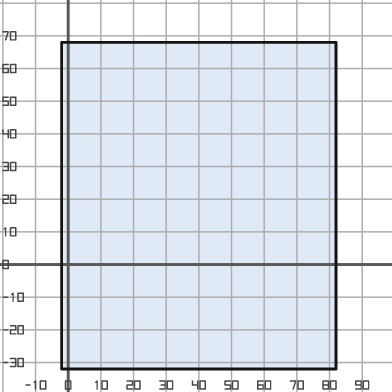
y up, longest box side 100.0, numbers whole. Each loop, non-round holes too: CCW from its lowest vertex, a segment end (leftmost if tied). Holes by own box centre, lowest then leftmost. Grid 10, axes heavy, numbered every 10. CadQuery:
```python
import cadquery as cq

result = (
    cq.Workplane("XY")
    .moveTo(-2.0, -32.0)
    .lineTo(82.0, -32.0)
    .lineTo(82.0, 68.0)
    .lineTo(-2.0, 68.0)
    .close()
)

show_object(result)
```